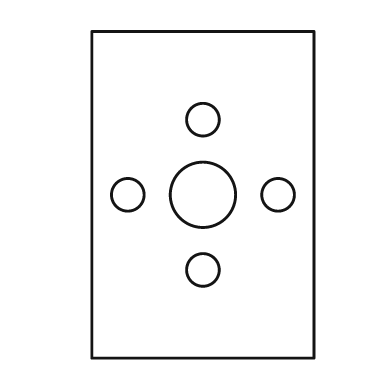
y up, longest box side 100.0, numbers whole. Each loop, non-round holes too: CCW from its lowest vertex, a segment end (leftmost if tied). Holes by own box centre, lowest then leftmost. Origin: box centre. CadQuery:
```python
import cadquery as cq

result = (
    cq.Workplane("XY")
    .moveTo(-34.0, -50.0)
    .lineTo(34.0, -50.0)
    .lineTo(34.0, 50.0)
    .lineTo(-34.0, 50.0)
    .close()
    .moveTo(0.0, -23.0)
    .circle(5.0)
    .moveTo(-23.0, 0.0)
    .circle(5.0)
    .moveTo(0.0, 0.0)
    .circle(10.0)
    .moveTo(23.0, 0.0)
    .circle(5.0)
    .moveTo(0.0, 23.0)
    .circle(5.0)
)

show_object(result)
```